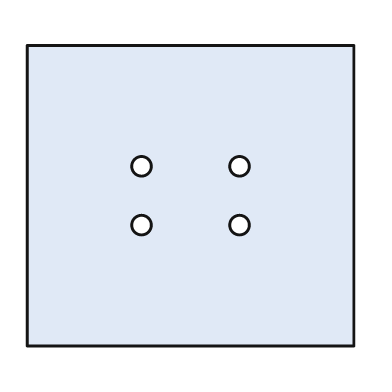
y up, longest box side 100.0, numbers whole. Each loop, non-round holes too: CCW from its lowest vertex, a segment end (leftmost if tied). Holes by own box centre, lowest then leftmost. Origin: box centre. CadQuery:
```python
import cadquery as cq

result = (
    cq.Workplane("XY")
    .moveTo(-50.0, -46.0)
    .lineTo(50.0, -46.0)
    .lineTo(50.0, 46.0)
    .lineTo(-50.0, 46.0)
    .close()
    .moveTo(-15.0, -9.0)
    .circle(3.0)
    .moveTo(15.0, -9.0)
    .circle(3.0)
    .moveTo(-15.0, 9.0)
    .circle(3.0)
    .moveTo(15.0, 9.0)
    .circle(3.0)
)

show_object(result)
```